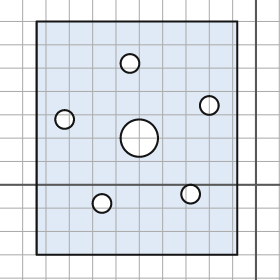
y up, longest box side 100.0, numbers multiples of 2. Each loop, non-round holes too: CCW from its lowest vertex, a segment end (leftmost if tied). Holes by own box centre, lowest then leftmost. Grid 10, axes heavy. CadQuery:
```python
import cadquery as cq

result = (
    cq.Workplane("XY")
    .moveTo(-94.0, -30.0)
    .lineTo(-8.0, -30.0)
    .lineTo(-8.0, 70.0)
    .lineTo(-94.0, 70.0)
    .close()
    .moveTo(-66.0, -8.0)
    .circle(4.0)
    .moveTo(-28.0, -4.0)
    .circle(4.0)
    .moveTo(-50.0, 20.0)
    .circle(8.0)
    .moveTo(-82.0, 28.0)
    .circle(4.0)
    .moveTo(-20.0, 34.0)
    .circle(4.0)
    .moveTo(-54.0, 52.0)
    .circle(4.0)
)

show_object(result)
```